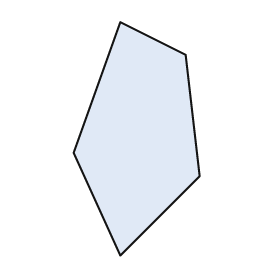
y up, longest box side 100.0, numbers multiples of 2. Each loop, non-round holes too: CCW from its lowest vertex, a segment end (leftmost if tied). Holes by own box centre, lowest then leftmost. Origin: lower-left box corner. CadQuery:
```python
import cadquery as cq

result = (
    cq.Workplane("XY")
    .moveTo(20.0, 0.0)
    .lineTo(54.0, 34.0)
    .lineTo(48.0, 86.0)
    .lineTo(20.0, 100.0)
    .lineTo(0.0, 44.0)
    .close()
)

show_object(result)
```